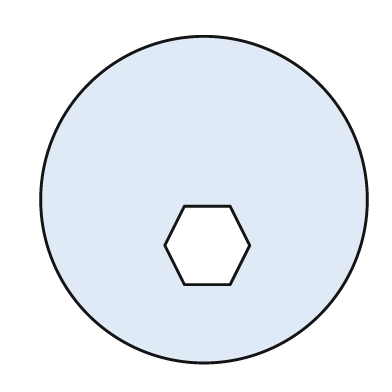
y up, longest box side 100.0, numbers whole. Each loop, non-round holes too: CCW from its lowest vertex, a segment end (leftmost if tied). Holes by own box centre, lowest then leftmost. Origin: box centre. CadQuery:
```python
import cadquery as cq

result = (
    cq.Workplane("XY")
    .moveTo(0.0, 0.0)
    .circle(50.0)
    .moveTo(-6.0, -26.0)
    .lineTo(8.0, -26.0)
    .lineTo(14.0, -14.0)
    .lineTo(8.0, -2.0)
    .lineTo(-6.0, -2.0)
    .lineTo(-12.0, -14.0)
    .close()
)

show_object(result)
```